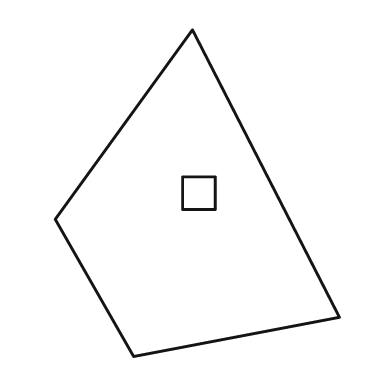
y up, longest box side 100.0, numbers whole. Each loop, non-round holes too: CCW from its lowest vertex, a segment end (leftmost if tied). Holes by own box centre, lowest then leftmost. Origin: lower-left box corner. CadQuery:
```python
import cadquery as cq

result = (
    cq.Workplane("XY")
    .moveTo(24.0, 0.0)
    .lineTo(87.0, 12.0)
    .lineTo(42.0, 100.0)
    .lineTo(0.0, 42.0)
    .close()
    .moveTo(39.0, 45.0)
    .lineTo(49.0, 45.0)
    .lineTo(49.0, 55.0)
    .lineTo(39.0, 55.0)
    .close()
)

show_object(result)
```